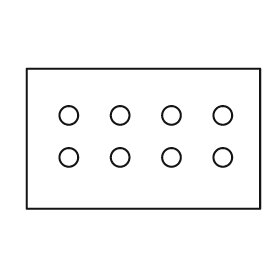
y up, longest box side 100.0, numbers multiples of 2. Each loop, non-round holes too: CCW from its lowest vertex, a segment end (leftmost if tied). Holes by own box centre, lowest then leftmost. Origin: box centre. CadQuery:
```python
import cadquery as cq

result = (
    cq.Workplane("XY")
    .moveTo(-50.0, -30.0)
    .lineTo(50.0, -30.0)
    .lineTo(50.0, 30.0)
    .lineTo(-50.0, 30.0)
    .close()
    .moveTo(-32.0, -8.0)
    .circle(4.0)
    .moveTo(-10.0, -8.0)
    .circle(4.0)
    .moveTo(12.0, -8.0)
    .circle(4.0)
    .moveTo(34.0, -8.0)
    .circle(4.0)
    .moveTo(-32.0, 10.0)
    .circle(4.0)
    .moveTo(-10.0, 10.0)
    .circle(4.0)
    .moveTo(12.0, 10.0)
    .circle(4.0)
    .moveTo(34.0, 10.0)
    .circle(4.0)
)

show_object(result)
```